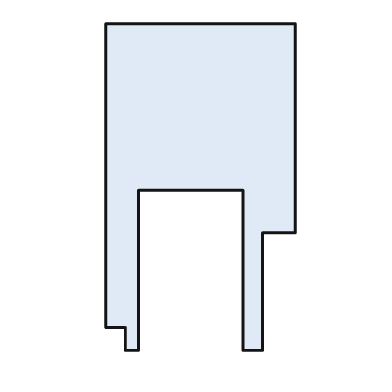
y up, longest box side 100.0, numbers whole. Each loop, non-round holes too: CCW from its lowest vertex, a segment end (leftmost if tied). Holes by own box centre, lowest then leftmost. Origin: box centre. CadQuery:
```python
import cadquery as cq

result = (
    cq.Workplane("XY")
    .moveTo(-23.0, -50.0)
    .lineTo(-19.0, -50.0)
    .lineTo(-19.0, -1.0)
    .lineTo(13.0, -1.0)
    .lineTo(13.0, -50.0)
    .lineTo(19.0, -50.0)
    .lineTo(19.0, -14.0)
    .lineTo(29.0, -14.0)
    .lineTo(29.0, 50.0)
    .lineTo(-29.0, 50.0)
    .lineTo(-29.0, -43.0)
    .lineTo(-23.0, -43.0)
    .close()
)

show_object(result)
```